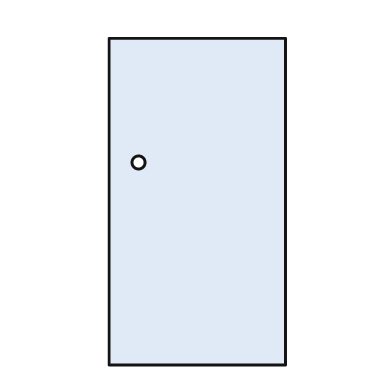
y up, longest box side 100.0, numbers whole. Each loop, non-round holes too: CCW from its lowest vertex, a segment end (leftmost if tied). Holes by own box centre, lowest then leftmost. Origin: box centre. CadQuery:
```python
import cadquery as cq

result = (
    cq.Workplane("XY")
    .moveTo(-27.0, -50.0)
    .lineTo(27.0, -50.0)
    .lineTo(27.0, 50.0)
    .lineTo(-27.0, 50.0)
    .close()
    .moveTo(-18.0, 12.0)
    .circle(2.0)
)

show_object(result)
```